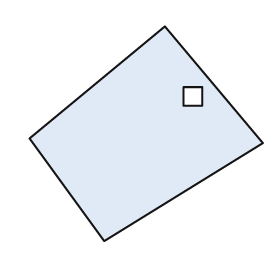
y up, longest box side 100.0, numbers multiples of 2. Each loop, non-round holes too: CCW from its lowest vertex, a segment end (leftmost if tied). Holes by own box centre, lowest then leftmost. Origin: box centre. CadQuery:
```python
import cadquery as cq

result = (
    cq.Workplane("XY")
    .moveTo(-18.0, -46.0)
    .lineTo(50.0, -4.0)
    .lineTo(8.0, 46.0)
    .lineTo(-50.0, -2.0)
    .close()
    .moveTo(16.0, 12.0)
    .lineTo(24.0, 12.0)
    .lineTo(24.0, 20.0)
    .lineTo(16.0, 20.0)
    .close()
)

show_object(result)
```